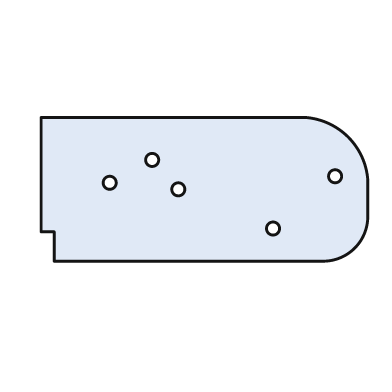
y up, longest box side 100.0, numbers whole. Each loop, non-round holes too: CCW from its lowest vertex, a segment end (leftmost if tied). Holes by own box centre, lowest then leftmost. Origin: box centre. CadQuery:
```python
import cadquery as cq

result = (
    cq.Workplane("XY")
    .moveTo(-46.0, -22.0)
    .lineTo(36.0, -22.0)
    .threePointArc((46.0, -18.0), (50.0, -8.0))
    .lineTo(50.0, 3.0)
    .threePointArc((44.0, 16.0), (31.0, 22.0))
    .lineTo(-50.0, 22.0)
    .lineTo(-50.0, -13.0)
    .lineTo(-46.0, -13.0)
    .close()
    .moveTo(21.0, -12.0)
    .circle(2.0)
    .moveTo(-8.0, 0.0)
    .circle(2.0)
    .moveTo(-29.0, 2.0)
    .circle(2.0)
    .moveTo(40.0, 4.0)
    .circle(2.0)
    .moveTo(-16.0, 9.0)
    .circle(2.0)
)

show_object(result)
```